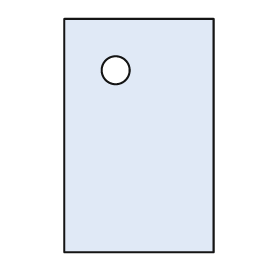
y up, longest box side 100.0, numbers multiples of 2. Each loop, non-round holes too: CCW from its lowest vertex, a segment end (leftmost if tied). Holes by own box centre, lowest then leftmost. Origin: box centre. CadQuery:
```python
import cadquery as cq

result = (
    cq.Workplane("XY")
    .moveTo(-32.0, -50.0)
    .lineTo(32.0, -50.0)
    .lineTo(32.0, 50.0)
    .lineTo(-32.0, 50.0)
    .close()
    .moveTo(-10.0, 28.0)
    .circle(6.0)
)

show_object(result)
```